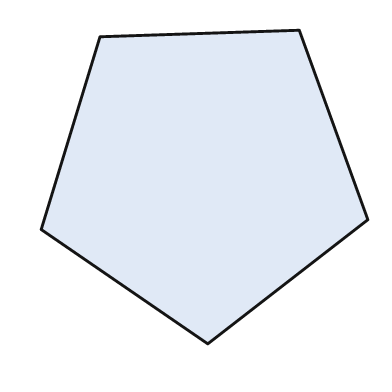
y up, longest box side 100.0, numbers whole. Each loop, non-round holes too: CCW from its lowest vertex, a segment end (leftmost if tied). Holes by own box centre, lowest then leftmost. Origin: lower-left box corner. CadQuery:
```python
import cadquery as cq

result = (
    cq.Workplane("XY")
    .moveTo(51.0, 0.0)
    .lineTo(100.0, 38.0)
    .lineTo(79.0, 96.0)
    .lineTo(18.0, 94.0)
    .lineTo(0.0, 35.0)
    .close()
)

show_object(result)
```